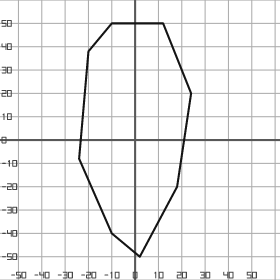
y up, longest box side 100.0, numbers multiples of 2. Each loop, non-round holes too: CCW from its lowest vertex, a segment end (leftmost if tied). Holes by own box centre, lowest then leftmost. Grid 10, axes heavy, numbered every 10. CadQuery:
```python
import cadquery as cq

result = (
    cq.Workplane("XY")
    .moveTo(2.0, -50.0)
    .lineTo(18.0, -20.0)
    .lineTo(24.0, 20.0)
    .lineTo(12.0, 50.0)
    .lineTo(-10.0, 50.0)
    .lineTo(-20.0, 38.0)
    .lineTo(-24.0, -8.0)
    .lineTo(-10.0, -40.0)
    .close()
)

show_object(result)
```